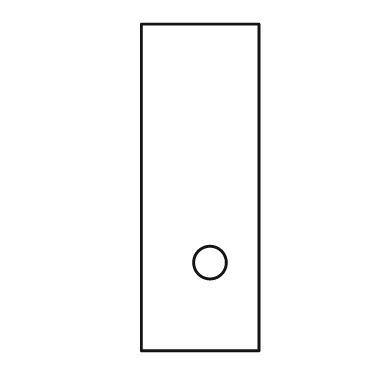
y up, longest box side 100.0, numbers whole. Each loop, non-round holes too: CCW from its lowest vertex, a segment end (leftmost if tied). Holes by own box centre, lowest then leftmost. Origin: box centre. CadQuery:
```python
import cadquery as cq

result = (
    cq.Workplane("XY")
    .moveTo(-18.0, -50.0)
    .lineTo(18.0, -50.0)
    .lineTo(18.0, 50.0)
    .lineTo(-18.0, 50.0)
    .close()
    .moveTo(3.0, -23.0)
    .circle(5.0)
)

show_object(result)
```